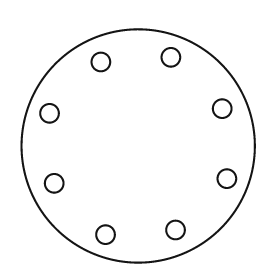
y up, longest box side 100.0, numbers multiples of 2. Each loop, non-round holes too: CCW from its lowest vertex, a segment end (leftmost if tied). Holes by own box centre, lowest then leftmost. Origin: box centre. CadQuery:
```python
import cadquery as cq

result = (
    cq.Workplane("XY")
    .moveTo(0.0, 0.0)
    .circle(50.0)
    .moveTo(-14.0, -38.0)
    .circle(4.0)
    .moveTo(16.0, -36.0)
    .circle(4.0)
    .moveTo(-36.0, -16.0)
    .circle(4.0)
    .moveTo(38.0, -14.0)
    .circle(4.0)
    .moveTo(-38.0, 14.0)
    .circle(4.0)
    .moveTo(36.0, 16.0)
    .circle(4.0)
    .moveTo(-16.0, 36.0)
    .circle(4.0)
    .moveTo(14.0, 38.0)
    .circle(4.0)
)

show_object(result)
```